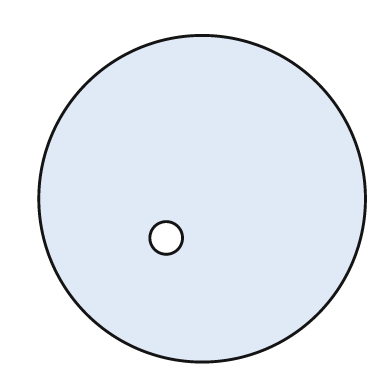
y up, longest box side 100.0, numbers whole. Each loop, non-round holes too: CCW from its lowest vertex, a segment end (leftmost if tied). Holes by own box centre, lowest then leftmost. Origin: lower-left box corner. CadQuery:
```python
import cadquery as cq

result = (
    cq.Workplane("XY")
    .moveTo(50.0, 50.0)
    .circle(50.0)
    .moveTo(39.0, 38.0)
    .circle(5.0)
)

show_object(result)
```